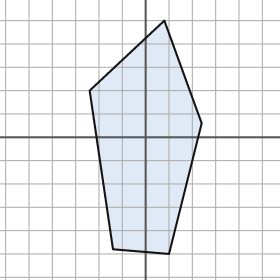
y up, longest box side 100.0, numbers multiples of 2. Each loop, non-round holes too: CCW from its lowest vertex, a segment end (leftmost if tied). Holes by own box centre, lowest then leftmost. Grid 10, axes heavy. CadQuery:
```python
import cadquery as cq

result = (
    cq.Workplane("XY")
    .moveTo(10.0, -50.0)
    .lineTo(24.0, 6.0)
    .lineTo(8.0, 50.0)
    .lineTo(-24.0, 20.0)
    .lineTo(-14.0, -48.0)
    .close()
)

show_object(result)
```